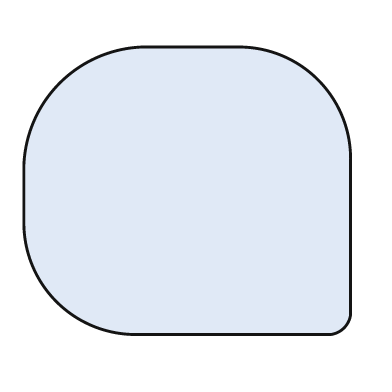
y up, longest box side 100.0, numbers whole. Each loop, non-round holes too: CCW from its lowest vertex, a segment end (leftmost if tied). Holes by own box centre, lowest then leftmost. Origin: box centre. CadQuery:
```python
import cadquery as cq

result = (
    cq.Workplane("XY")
    .moveTo(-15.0, -44.0)
    .lineTo(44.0, -44.0)
    .threePointArc((48.0, -42.0), (50.0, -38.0))
    .lineTo(50.0, 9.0)
    .threePointArc((40.0, 34.0), (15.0, 44.0))
    .lineTo(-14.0, 44.0)
    .threePointArc((-39.0, 33.0), (-50.0, 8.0))
    .lineTo(-50.0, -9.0)
    .threePointArc((-40.0, -34.0), (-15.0, -44.0))
    .close()
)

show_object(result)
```